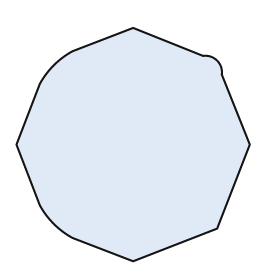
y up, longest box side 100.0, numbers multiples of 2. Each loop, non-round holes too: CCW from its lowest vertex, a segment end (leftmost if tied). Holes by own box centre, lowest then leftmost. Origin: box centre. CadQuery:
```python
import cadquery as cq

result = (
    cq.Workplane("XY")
    .moveTo(0.0, -50.0)
    .lineTo(36.0, -36.0)
    .lineTo(50.0, 0.0)
    .lineTo(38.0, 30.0)
    .threePointArc((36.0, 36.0), (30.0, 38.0))
    .lineTo(0.0, 50.0)
    .lineTo(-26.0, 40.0)
    .threePointArc((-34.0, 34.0), (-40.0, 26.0))
    .lineTo(-50.0, 0.0)
    .lineTo(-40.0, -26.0)
    .threePointArc((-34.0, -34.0), (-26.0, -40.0))
    .close()
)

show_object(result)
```